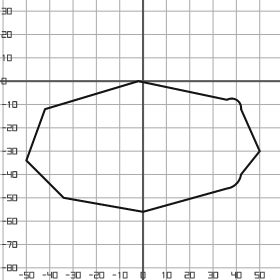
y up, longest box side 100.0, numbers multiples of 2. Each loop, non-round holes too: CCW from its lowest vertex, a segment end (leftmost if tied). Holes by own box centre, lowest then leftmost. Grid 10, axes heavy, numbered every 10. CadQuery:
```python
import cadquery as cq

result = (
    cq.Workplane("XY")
    .moveTo(0.0, -56.0)
    .lineTo(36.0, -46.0)
    .threePointArc((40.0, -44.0), (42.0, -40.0))
    .lineTo(50.0, -30.0)
    .lineTo(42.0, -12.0)
    .threePointArc((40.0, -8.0), (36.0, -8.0))
    .lineTo(-2.0, 0.0)
    .lineTo(-42.0, -12.0)
    .lineTo(-50.0, -34.0)
    .lineTo(-34.0, -50.0)
    .close()
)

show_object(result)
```